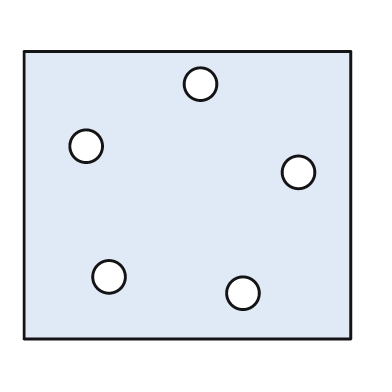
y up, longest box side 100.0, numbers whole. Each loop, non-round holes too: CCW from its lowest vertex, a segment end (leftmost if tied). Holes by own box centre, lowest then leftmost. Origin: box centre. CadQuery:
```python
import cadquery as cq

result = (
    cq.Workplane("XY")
    .moveTo(-50.0, -44.0)
    .lineTo(50.0, -44.0)
    .lineTo(50.0, 44.0)
    .lineTo(-50.0, 44.0)
    .close()
    .moveTo(17.0, -30.0)
    .circle(5.0)
    .moveTo(-24.0, -25.0)
    .circle(5.0)
    .moveTo(34.0, 7.0)
    .circle(5.0)
    .moveTo(-31.0, 15.0)
    .circle(5.0)
    .moveTo(4.0, 34.0)
    .circle(5.0)
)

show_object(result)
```